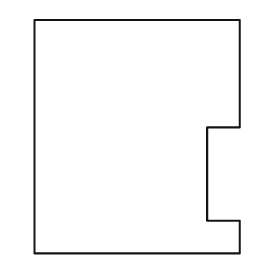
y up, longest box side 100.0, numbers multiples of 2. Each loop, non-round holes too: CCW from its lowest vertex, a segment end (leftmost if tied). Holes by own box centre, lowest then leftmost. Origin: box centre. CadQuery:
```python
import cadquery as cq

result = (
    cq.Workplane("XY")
    .moveTo(-44.0, -50.0)
    .lineTo(44.0, -50.0)
    .lineTo(44.0, -36.0)
    .lineTo(30.0, -36.0)
    .lineTo(30.0, 4.0)
    .lineTo(44.0, 4.0)
    .lineTo(44.0, 50.0)
    .lineTo(-44.0, 50.0)
    .close()
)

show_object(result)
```